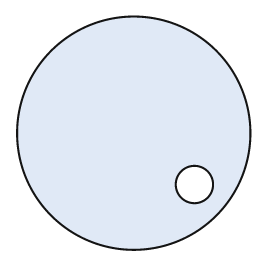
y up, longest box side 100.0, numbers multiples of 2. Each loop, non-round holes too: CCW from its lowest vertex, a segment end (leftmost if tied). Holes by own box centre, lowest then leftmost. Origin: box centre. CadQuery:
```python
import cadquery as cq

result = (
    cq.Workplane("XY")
    .moveTo(0.0, 0.0)
    .circle(50.0)
    .moveTo(26.0, -22.0)
    .circle(8.0)
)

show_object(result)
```